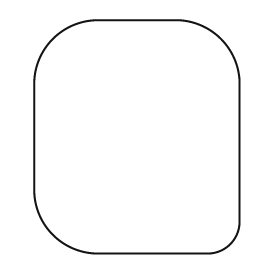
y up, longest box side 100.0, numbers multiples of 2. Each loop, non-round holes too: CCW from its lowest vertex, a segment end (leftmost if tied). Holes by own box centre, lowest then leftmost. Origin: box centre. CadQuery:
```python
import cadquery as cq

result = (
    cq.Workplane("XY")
    .moveTo(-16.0, -50.0)
    .lineTo(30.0, -50.0)
    .threePointArc((40.0, -46.0), (44.0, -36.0))
    .lineTo(44.0, 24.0)
    .threePointArc((36.0, 42.0), (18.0, 50.0))
    .lineTo(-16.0, 50.0)
    .threePointArc((-36.0, 42.0), (-44.0, 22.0))
    .lineTo(-44.0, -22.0)
    .threePointArc((-36.0, -42.0), (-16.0, -50.0))
    .close()
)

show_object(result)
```